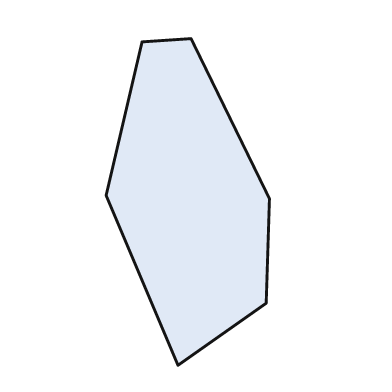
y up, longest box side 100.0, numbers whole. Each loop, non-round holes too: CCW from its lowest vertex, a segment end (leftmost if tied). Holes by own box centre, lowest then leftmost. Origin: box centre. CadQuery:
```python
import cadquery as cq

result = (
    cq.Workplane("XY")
    .moveTo(-3.0, -50.0)
    .lineTo(24.0, -31.0)
    .lineTo(25.0, 1.0)
    .lineTo(1.0, 50.0)
    .lineTo(-14.0, 49.0)
    .lineTo(-25.0, 2.0)
    .close()
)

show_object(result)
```